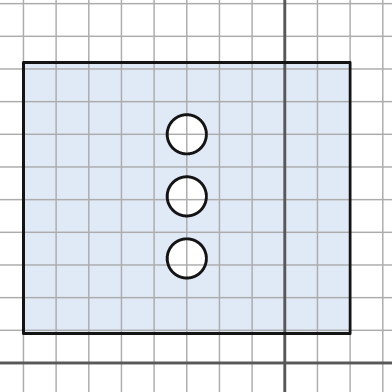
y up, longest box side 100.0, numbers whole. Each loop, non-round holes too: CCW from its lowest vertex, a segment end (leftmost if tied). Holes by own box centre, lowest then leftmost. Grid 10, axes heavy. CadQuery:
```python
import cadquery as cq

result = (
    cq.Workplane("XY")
    .moveTo(-80.0, 9.0)
    .lineTo(20.0, 9.0)
    .lineTo(20.0, 92.0)
    .lineTo(-80.0, 92.0)
    .close()
    .moveTo(-30.0, 32.0)
    .circle(6.0)
    .moveTo(-30.0, 51.0)
    .circle(6.0)
    .moveTo(-30.0, 70.0)
    .circle(6.0)
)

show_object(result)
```